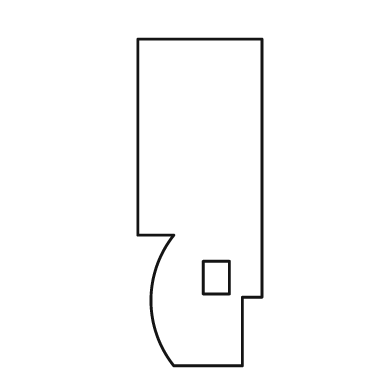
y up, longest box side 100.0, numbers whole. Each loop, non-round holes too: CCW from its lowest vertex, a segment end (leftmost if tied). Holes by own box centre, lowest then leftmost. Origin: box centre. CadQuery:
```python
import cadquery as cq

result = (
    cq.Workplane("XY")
    .moveTo(-8.0, -50.0)
    .lineTo(13.0, -50.0)
    .lineTo(13.0, -29.0)
    .lineTo(19.0, -29.0)
    .lineTo(19.0, 50.0)
    .lineTo(-19.0, 50.0)
    .lineTo(-19.0, -10.0)
    .lineTo(-8.0, -10.0)
    .threePointArc((-15.0, -30.0), (-8.0, -50.0))
    .close()
    .moveTo(1.0, -28.0)
    .lineTo(9.0, -28.0)
    .lineTo(9.0, -18.0)
    .lineTo(1.0, -18.0)
    .close()
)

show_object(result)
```